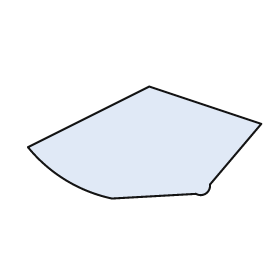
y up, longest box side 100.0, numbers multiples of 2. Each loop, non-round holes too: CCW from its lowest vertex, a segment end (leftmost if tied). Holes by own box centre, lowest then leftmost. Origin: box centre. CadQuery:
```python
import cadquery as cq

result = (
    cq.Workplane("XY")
    .moveTo(-14.0, -24.0)
    .lineTo(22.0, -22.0)
    .threePointArc((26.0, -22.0), (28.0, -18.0))
    .lineTo(50.0, 8.0)
    .lineTo(2.0, 24.0)
    .lineTo(-50.0, -2.0)
    .threePointArc((-34.0, -16.0), (-14.0, -24.0))
    .close()
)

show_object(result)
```